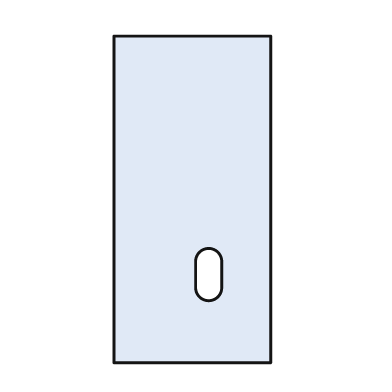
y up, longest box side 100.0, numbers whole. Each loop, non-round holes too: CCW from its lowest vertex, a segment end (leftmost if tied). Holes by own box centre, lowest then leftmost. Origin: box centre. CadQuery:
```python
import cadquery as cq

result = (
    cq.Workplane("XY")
    .moveTo(-24.0, -50.0)
    .lineTo(24.0, -50.0)
    .lineTo(24.0, 50.0)
    .lineTo(-24.0, 50.0)
    .close()
    .moveTo(1.0, -27.0)
    .threePointArc((5.0, -31.0), (9.0, -27.0))
    .lineTo(9.0, -19.0)
    .threePointArc((5.0, -15.0), (1.0, -19.0))
    .close()
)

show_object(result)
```